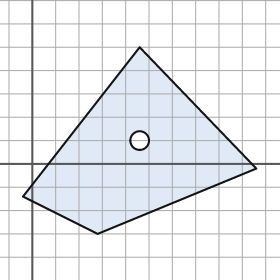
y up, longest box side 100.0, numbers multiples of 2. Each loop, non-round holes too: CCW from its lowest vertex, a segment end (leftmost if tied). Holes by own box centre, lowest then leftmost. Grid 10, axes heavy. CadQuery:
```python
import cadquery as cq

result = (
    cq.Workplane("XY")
    .moveTo(28.0, -30.0)
    .lineTo(96.0, -2.0)
    .lineTo(46.0, 50.0)
    .lineTo(-4.0, -14.0)
    .close()
    .moveTo(46.0, 10.0)
    .circle(4.0)
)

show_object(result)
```